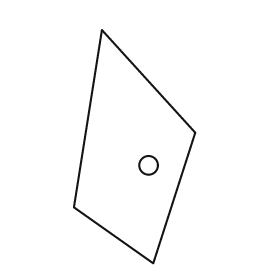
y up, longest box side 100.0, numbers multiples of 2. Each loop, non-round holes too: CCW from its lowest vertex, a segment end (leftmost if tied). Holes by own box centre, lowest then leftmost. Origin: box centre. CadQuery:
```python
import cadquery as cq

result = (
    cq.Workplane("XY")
    .moveTo(8.0, -50.0)
    .lineTo(26.0, 6.0)
    .lineTo(-14.0, 50.0)
    .lineTo(-26.0, -26.0)
    .close()
    .moveTo(6.0, -8.0)
    .circle(4.0)
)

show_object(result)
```